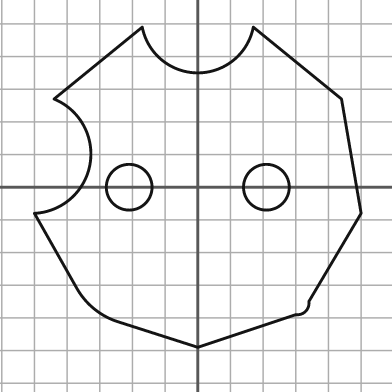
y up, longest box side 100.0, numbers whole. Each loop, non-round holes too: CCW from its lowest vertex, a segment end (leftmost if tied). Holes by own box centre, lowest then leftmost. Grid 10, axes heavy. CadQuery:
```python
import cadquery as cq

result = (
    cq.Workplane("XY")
    .moveTo(0.0, -49.0)
    .lineTo(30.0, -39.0)
    .threePointArc((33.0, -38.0), (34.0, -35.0))
    .lineTo(50.0, -8.0)
    .lineTo(44.0, 27.0)
    .lineTo(17.0, 49.0)
    .threePointArc((0.0, 35.0), (-17.0, 49.0))
    .lineTo(-44.0, 27.0)
    .threePointArc((-33.0, 7.0), (-50.0, -8.0))
    .lineTo(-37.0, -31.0)
    .threePointArc((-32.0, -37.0), (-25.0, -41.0))
    .close()
    .moveTo(-21.0, 0.0)
    .circle(7.0)
    .moveTo(21.0, 0.0)
    .circle(7.0)
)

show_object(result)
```